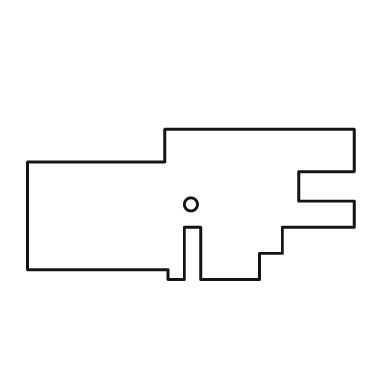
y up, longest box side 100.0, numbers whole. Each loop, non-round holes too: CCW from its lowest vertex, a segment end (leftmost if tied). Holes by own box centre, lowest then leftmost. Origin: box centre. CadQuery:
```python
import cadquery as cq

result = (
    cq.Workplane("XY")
    .moveTo(-7.0, -23.0)
    .lineTo(-2.0, -23.0)
    .lineTo(-2.0, -7.0)
    .lineTo(3.0, -7.0)
    .lineTo(3.0, -23.0)
    .lineTo(21.0, -23.0)
    .lineTo(21.0, -15.0)
    .lineTo(28.0, -15.0)
    .lineTo(28.0, -7.0)
    .lineTo(50.0, -7.0)
    .lineTo(50.0, 1.0)
    .lineTo(33.0, 1.0)
    .lineTo(33.0, 10.0)
    .lineTo(50.0, 10.0)
    .lineTo(50.0, 23.0)
    .lineTo(-8.0, 23.0)
    .lineTo(-8.0, 13.0)
    .lineTo(-50.0, 13.0)
    .lineTo(-50.0, -20.0)
    .lineTo(-7.0, -20.0)
    .close()
    .moveTo(0.0, 0.0)
    .circle(2.0)
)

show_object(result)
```